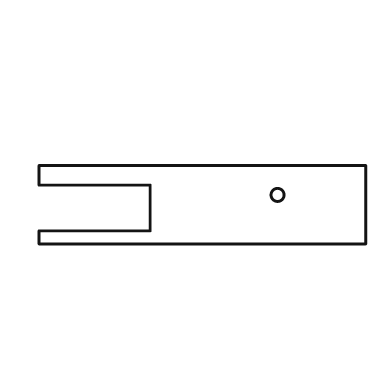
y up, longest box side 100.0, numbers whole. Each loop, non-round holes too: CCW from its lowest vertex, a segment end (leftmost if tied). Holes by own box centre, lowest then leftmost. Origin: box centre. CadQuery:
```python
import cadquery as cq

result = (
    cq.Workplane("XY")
    .moveTo(-50.0, -12.0)
    .lineTo(50.0, -12.0)
    .lineTo(50.0, 12.0)
    .lineTo(-50.0, 12.0)
    .lineTo(-50.0, 6.0)
    .lineTo(-16.0, 6.0)
    .lineTo(-16.0, -8.0)
    .lineTo(-50.0, -8.0)
    .close()
    .moveTo(23.0, 3.0)
    .circle(2.0)
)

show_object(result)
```